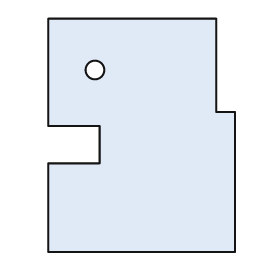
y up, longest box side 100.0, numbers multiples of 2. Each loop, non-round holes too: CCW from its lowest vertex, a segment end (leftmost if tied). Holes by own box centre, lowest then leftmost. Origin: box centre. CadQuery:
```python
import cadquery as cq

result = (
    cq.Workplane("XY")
    .moveTo(-40.0, -50.0)
    .lineTo(40.0, -50.0)
    .lineTo(40.0, 10.0)
    .lineTo(32.0, 10.0)
    .lineTo(32.0, 50.0)
    .lineTo(-40.0, 50.0)
    .lineTo(-40.0, 4.0)
    .lineTo(-18.0, 4.0)
    .lineTo(-18.0, -12.0)
    .lineTo(-40.0, -12.0)
    .close()
    .moveTo(-20.0, 28.0)
    .circle(4.0)
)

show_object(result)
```